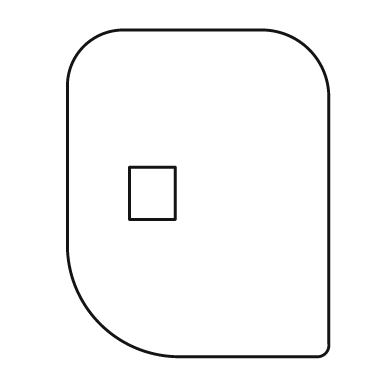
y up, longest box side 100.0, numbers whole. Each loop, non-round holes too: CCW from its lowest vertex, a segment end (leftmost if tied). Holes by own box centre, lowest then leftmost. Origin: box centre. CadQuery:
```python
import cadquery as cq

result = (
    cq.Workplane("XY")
    .moveTo(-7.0, -50.0)
    .lineTo(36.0, -50.0)
    .threePointArc((39.0, -49.0), (40.0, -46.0))
    .lineTo(40.0, 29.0)
    .threePointArc((34.0, 44.0), (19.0, 50.0))
    .lineTo(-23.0, 50.0)
    .threePointArc((-35.0, 45.0), (-40.0, 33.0))
    .lineTo(-40.0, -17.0)
    .threePointArc((-30.0, -40.0), (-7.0, -50.0))
    .close()
    .moveTo(-21.0, -8.0)
    .lineTo(-7.0, -8.0)
    .lineTo(-7.0, 8.0)
    .lineTo(-21.0, 8.0)
    .close()
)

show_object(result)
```